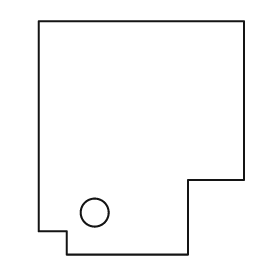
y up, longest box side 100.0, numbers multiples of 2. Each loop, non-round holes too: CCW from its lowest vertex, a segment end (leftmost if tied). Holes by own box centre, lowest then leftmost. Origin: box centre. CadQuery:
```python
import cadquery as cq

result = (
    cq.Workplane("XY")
    .moveTo(-32.0, -50.0)
    .lineTo(20.0, -50.0)
    .lineTo(20.0, -18.0)
    .lineTo(44.0, -18.0)
    .lineTo(44.0, 50.0)
    .lineTo(-44.0, 50.0)
    .lineTo(-44.0, -40.0)
    .lineTo(-32.0, -40.0)
    .close()
    .moveTo(-20.0, -32.0)
    .circle(6.0)
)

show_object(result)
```